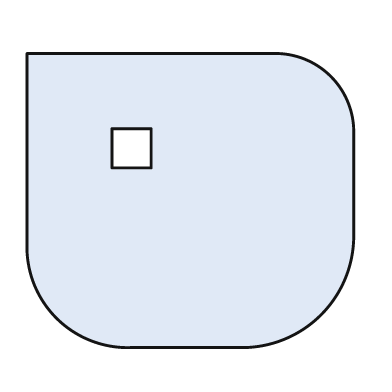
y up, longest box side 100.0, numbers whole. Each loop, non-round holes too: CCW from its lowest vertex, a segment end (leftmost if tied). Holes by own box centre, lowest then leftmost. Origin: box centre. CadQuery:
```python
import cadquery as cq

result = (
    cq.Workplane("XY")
    .moveTo(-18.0, -45.0)
    .lineTo(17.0, -45.0)
    .threePointArc((40.0, -35.0), (50.0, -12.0))
    .lineTo(50.0, 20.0)
    .threePointArc((43.0, 38.0), (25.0, 45.0))
    .lineTo(-50.0, 45.0)
    .lineTo(-50.0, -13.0)
    .threePointArc((-41.0, -36.0), (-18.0, -45.0))
    .close()
    .moveTo(-24.0, 10.0)
    .lineTo(-12.0, 10.0)
    .lineTo(-12.0, 22.0)
    .lineTo(-24.0, 22.0)
    .close()
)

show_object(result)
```